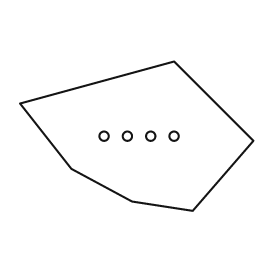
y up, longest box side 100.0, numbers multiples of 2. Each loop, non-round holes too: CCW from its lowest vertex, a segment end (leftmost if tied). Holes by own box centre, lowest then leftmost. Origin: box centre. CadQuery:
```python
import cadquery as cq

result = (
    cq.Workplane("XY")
    .moveTo(24.0, -32.0)
    .lineTo(50.0, -2.0)
    .lineTo(16.0, 32.0)
    .lineTo(-50.0, 14.0)
    .lineTo(-28.0, -14.0)
    .lineTo(-2.0, -28.0)
    .close()
    .moveTo(-14.0, 0.0)
    .circle(2.0)
    .moveTo(-4.0, 0.0)
    .circle(2.0)
    .moveTo(6.0, 0.0)
    .circle(2.0)
    .moveTo(16.0, 0.0)
    .circle(2.0)
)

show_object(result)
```